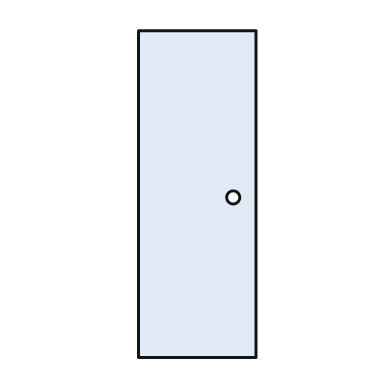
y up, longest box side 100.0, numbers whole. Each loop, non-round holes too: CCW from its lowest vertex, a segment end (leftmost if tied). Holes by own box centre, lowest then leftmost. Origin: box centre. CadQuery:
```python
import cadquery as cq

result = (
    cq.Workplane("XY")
    .moveTo(-18.0, -50.0)
    .lineTo(18.0, -50.0)
    .lineTo(18.0, 50.0)
    .lineTo(-18.0, 50.0)
    .close()
    .moveTo(11.0, -1.0)
    .circle(2.0)
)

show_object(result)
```